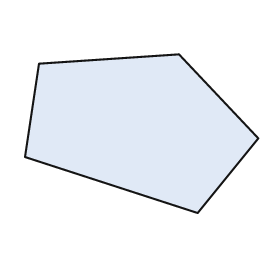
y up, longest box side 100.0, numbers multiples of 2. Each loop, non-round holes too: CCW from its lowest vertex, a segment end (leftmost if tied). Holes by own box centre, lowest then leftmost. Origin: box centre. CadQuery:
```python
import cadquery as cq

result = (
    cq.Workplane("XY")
    .moveTo(24.0, -34.0)
    .lineTo(50.0, -2.0)
    .lineTo(16.0, 34.0)
    .lineTo(-44.0, 30.0)
    .lineTo(-50.0, -10.0)
    .close()
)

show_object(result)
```